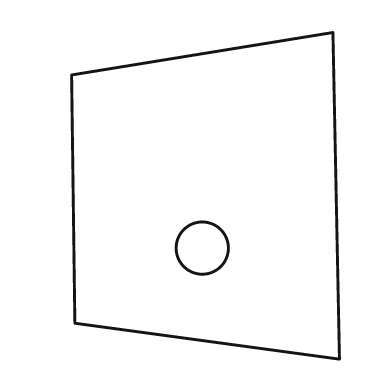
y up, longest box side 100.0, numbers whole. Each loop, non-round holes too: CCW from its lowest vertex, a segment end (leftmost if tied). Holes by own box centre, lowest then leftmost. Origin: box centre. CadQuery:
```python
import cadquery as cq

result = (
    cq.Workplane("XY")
    .moveTo(41.0, -50.0)
    .lineTo(39.0, 50.0)
    .lineTo(-41.0, 37.0)
    .lineTo(-40.0, -39.0)
    .close()
    .moveTo(-1.0, -16.0)
    .circle(8.0)
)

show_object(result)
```